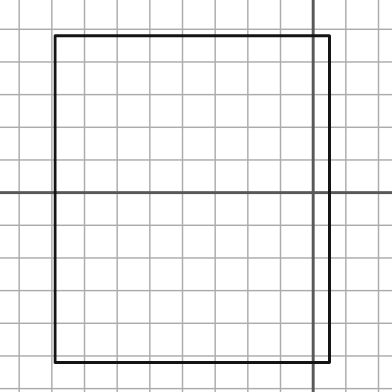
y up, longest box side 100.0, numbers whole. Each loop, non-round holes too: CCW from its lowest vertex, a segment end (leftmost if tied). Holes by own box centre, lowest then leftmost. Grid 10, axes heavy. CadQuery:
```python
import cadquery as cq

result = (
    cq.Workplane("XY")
    .moveTo(-79.0, -52.0)
    .lineTo(5.0, -52.0)
    .lineTo(5.0, 48.0)
    .lineTo(-79.0, 48.0)
    .close()
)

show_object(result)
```